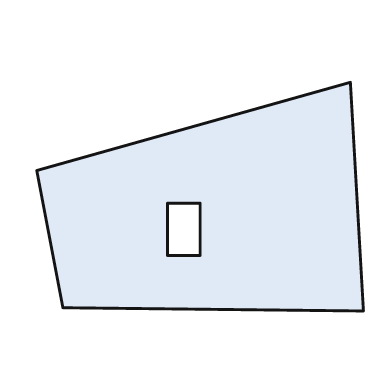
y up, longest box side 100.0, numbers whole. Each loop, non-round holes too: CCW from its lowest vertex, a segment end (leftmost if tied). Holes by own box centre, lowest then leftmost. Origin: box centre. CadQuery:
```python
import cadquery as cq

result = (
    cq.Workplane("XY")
    .moveTo(50.0, -35.0)
    .lineTo(46.0, 35.0)
    .lineTo(-50.0, 8.0)
    .lineTo(-42.0, -34.0)
    .close()
    .moveTo(-10.0, -18.0)
    .lineTo(0.0, -18.0)
    .lineTo(0.0, -2.0)
    .lineTo(-10.0, -2.0)
    .close()
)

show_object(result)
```